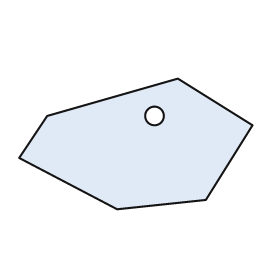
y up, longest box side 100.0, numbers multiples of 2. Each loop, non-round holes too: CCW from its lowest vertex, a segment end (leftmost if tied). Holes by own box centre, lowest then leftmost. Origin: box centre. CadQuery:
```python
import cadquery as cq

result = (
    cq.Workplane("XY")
    .moveTo(-8.0, -28.0)
    .lineTo(30.0, -24.0)
    .lineTo(50.0, 8.0)
    .lineTo(18.0, 28.0)
    .lineTo(-38.0, 12.0)
    .lineTo(-50.0, -6.0)
    .close()
    .moveTo(8.0, 12.0)
    .circle(4.0)
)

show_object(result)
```